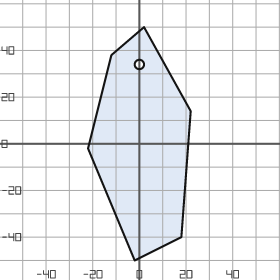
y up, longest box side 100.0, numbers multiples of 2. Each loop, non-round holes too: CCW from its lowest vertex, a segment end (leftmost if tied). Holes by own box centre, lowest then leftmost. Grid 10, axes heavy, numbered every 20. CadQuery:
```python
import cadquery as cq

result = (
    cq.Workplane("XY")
    .moveTo(-2.0, -50.0)
    .lineTo(18.0, -40.0)
    .lineTo(22.0, 14.0)
    .lineTo(2.0, 50.0)
    .lineTo(-12.0, 38.0)
    .lineTo(-22.0, -2.0)
    .close()
    .moveTo(0.0, 34.0)
    .circle(2.0)
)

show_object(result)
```